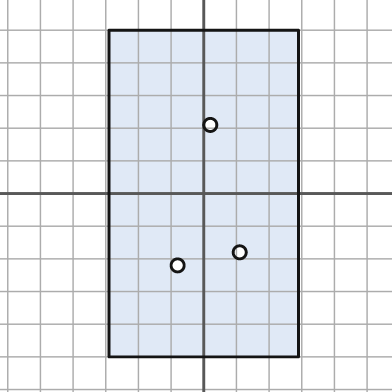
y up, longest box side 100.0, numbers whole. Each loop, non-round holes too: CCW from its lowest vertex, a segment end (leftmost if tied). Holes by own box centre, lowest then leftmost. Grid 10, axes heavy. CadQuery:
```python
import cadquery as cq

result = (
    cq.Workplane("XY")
    .moveTo(-29.0, -50.0)
    .lineTo(29.0, -50.0)
    .lineTo(29.0, 50.0)
    .lineTo(-29.0, 50.0)
    .close()
    .moveTo(-8.0, -22.0)
    .circle(2.0)
    .moveTo(11.0, -18.0)
    .circle(2.0)
    .moveTo(2.0, 21.0)
    .circle(2.0)
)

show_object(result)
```